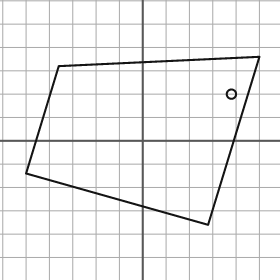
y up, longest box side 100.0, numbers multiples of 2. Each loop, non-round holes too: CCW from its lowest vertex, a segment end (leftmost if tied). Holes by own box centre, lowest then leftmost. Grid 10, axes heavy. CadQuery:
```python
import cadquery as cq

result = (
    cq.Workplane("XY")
    .moveTo(28.0, -36.0)
    .lineTo(50.0, 36.0)
    .lineTo(-36.0, 32.0)
    .lineTo(-50.0, -14.0)
    .close()
    .moveTo(38.0, 20.0)
    .circle(2.0)
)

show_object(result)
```